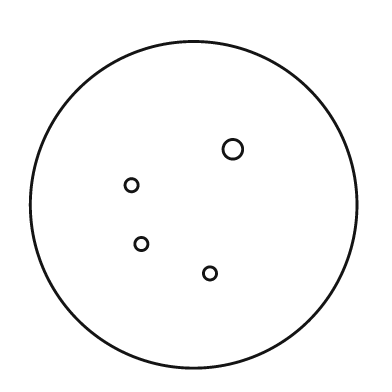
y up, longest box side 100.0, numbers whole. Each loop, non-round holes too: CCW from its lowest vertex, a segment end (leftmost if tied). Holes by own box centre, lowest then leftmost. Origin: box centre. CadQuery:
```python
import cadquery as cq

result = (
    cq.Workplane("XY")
    .moveTo(0.0, 0.0)
    .circle(50.0)
    .moveTo(5.0, -21.0)
    .circle(2.0)
    .moveTo(-16.0, -12.0)
    .circle(2.0)
    .moveTo(-19.0, 6.0)
    .circle(2.0)
    .moveTo(12.0, 17.0)
    .circle(3.0)
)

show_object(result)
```